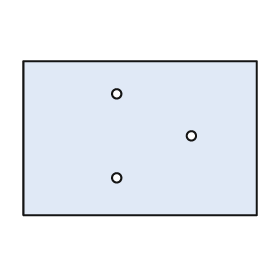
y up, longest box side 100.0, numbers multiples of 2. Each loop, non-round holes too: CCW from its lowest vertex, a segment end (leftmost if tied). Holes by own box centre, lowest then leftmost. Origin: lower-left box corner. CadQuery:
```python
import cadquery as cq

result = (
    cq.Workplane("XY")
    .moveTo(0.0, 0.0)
    .lineTo(100.0, 0.0)
    .lineTo(100.0, 66.0)
    .lineTo(0.0, 66.0)
    .close()
    .moveTo(40.0, 16.0)
    .circle(2.0)
    .moveTo(72.0, 34.0)
    .circle(2.0)
    .moveTo(40.0, 52.0)
    .circle(2.0)
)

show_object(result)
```